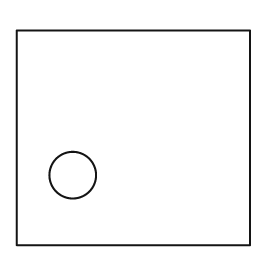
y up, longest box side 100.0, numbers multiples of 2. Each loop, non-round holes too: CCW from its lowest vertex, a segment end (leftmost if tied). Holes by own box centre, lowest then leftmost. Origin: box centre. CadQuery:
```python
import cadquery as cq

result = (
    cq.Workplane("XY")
    .moveTo(-50.0, -46.0)
    .lineTo(50.0, -46.0)
    .lineTo(50.0, 46.0)
    .lineTo(-50.0, 46.0)
    .close()
    .moveTo(-26.0, -16.0)
    .circle(10.0)
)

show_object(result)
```